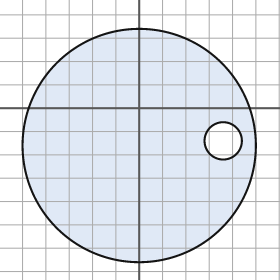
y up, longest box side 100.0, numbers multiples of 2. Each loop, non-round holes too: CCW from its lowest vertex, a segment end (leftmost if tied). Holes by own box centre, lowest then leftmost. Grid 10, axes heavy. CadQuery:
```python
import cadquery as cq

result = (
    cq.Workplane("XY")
    .moveTo(0.0, -16.0)
    .circle(50.0)
    .moveTo(36.0, -14.0)
    .circle(8.0)
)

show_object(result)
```